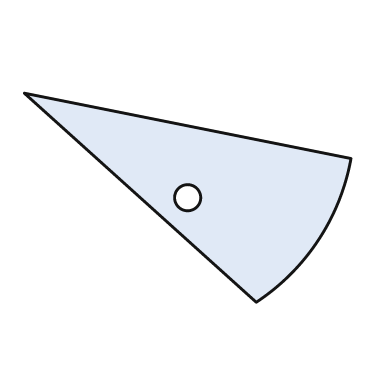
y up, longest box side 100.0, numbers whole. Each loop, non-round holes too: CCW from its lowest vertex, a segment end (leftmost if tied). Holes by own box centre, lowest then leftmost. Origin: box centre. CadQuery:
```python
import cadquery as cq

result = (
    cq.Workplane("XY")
    .moveTo(21.0, -32.0)
    .threePointArc((40.0, -13.0), (50.0, 12.0))
    .lineTo(-50.0, 32.0)
    .close()
    .moveTo(0.0, 0.0)
    .circle(4.0)
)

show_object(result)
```